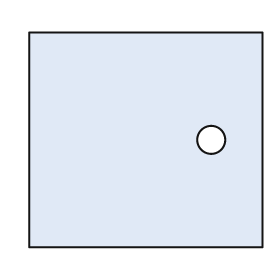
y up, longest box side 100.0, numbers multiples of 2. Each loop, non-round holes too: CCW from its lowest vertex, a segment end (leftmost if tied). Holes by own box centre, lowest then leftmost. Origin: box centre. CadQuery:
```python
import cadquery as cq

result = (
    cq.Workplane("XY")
    .moveTo(-50.0, -46.0)
    .lineTo(50.0, -46.0)
    .lineTo(50.0, 46.0)
    .lineTo(-50.0, 46.0)
    .close()
    .moveTo(28.0, 0.0)
    .circle(6.0)
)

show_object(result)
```